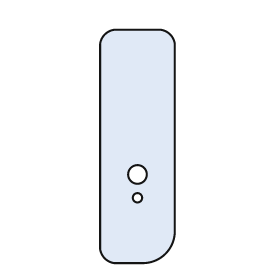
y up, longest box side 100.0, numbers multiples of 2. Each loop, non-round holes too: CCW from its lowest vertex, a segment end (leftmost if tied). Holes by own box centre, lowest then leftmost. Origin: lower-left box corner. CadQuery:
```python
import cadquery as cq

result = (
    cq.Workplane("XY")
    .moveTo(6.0, 0.0)
    .lineTo(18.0, 0.0)
    .threePointArc((28.0, 4.0), (32.0, 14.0))
    .lineTo(32.0, 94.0)
    .threePointArc((30.0, 98.0), (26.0, 100.0))
    .lineTo(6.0, 100.0)
    .threePointArc((2.0, 98.0), (0.0, 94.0))
    .lineTo(0.0, 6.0)
    .threePointArc((2.0, 2.0), (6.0, 0.0))
    .close()
    .moveTo(16.0, 28.0)
    .circle(2.0)
    .moveTo(16.0, 38.0)
    .circle(4.0)
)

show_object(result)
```